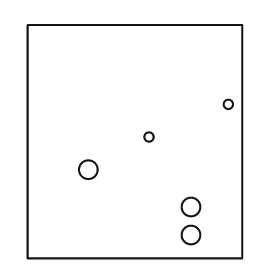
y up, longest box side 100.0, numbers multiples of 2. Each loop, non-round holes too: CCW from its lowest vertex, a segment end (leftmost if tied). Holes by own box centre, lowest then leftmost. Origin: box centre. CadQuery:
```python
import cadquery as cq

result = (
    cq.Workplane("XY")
    .moveTo(-46.0, -50.0)
    .lineTo(46.0, -50.0)
    .lineTo(46.0, 50.0)
    .lineTo(-46.0, 50.0)
    .close()
    .moveTo(24.0, -40.0)
    .circle(4.0)
    .moveTo(24.0, -28.0)
    .circle(4.0)
    .moveTo(-20.0, -12.0)
    .circle(4.0)
    .moveTo(6.0, 2.0)
    .circle(2.0)
    .moveTo(40.0, 16.0)
    .circle(2.0)
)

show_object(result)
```